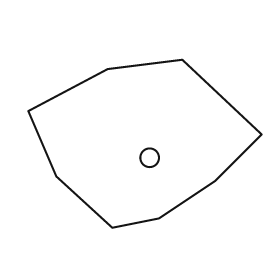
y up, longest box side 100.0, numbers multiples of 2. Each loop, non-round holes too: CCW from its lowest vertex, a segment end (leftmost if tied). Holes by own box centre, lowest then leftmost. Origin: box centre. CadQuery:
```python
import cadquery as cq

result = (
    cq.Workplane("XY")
    .moveTo(-14.0, -36.0)
    .lineTo(6.0, -32.0)
    .lineTo(30.0, -16.0)
    .lineTo(50.0, 4.0)
    .lineTo(16.0, 36.0)
    .lineTo(-16.0, 32.0)
    .lineTo(-50.0, 14.0)
    .lineTo(-38.0, -14.0)
    .close()
    .moveTo(2.0, -6.0)
    .circle(4.0)
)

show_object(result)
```